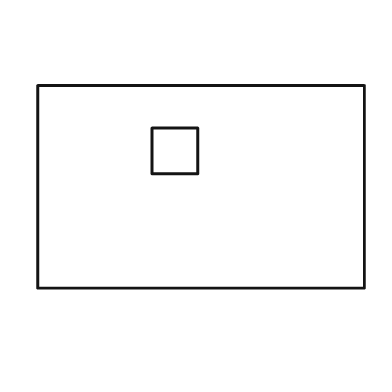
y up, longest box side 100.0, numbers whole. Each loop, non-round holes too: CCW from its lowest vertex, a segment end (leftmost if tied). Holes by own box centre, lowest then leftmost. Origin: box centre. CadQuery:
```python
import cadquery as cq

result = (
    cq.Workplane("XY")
    .moveTo(-50.0, -31.0)
    .lineTo(50.0, -31.0)
    .lineTo(50.0, 31.0)
    .lineTo(-50.0, 31.0)
    .close()
    .moveTo(-15.0, 4.0)
    .lineTo(-1.0, 4.0)
    .lineTo(-1.0, 18.0)
    .lineTo(-15.0, 18.0)
    .close()
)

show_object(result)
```